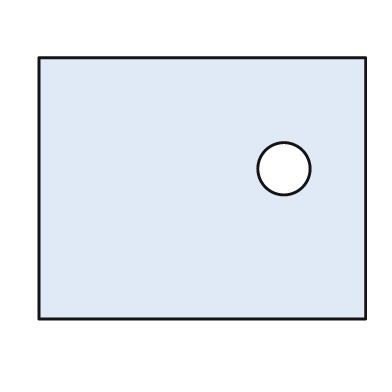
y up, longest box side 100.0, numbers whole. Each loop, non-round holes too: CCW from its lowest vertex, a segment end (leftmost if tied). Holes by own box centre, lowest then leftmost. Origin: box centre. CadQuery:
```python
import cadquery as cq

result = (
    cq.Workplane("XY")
    .moveTo(-50.0, -40.0)
    .lineTo(50.0, -40.0)
    .lineTo(50.0, 40.0)
    .lineTo(-50.0, 40.0)
    .close()
    .moveTo(25.0, 6.0)
    .circle(8.0)
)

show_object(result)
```